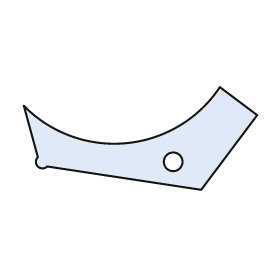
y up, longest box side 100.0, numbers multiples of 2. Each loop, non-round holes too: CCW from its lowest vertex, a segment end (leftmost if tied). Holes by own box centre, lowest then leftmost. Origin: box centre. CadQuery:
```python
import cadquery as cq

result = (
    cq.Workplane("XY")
    .moveTo(26.0, -22.0)
    .lineTo(50.0, 10.0)
    .lineTo(34.0, 22.0)
    .threePointArc((-6.0, -2.0), (-50.0, 14.0))
    .lineTo(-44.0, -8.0)
    .threePointArc((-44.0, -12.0), (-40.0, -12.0))
    .close()
    .moveTo(14.0, -10.0)
    .circle(4.0)
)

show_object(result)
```